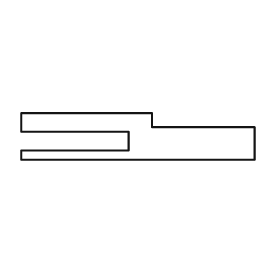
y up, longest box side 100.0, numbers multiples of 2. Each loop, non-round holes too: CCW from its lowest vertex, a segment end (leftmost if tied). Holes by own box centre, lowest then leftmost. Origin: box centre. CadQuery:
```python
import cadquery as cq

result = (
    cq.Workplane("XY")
    .moveTo(-50.0, -10.0)
    .lineTo(50.0, -10.0)
    .lineTo(50.0, 4.0)
    .lineTo(6.0, 4.0)
    .lineTo(6.0, 10.0)
    .lineTo(-50.0, 10.0)
    .lineTo(-50.0, 2.0)
    .lineTo(-4.0, 2.0)
    .lineTo(-4.0, -6.0)
    .lineTo(-50.0, -6.0)
    .close()
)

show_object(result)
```